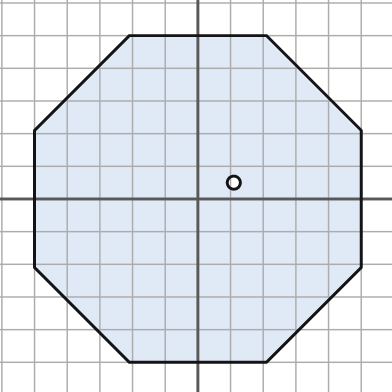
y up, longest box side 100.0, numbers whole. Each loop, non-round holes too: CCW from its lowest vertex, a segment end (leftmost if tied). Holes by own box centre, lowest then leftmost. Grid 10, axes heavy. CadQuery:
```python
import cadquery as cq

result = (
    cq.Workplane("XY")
    .moveTo(-21.0, -50.0)
    .lineTo(21.0, -50.0)
    .lineTo(50.0, -21.0)
    .lineTo(50.0, 21.0)
    .lineTo(21.0, 50.0)
    .lineTo(-21.0, 50.0)
    .lineTo(-50.0, 21.0)
    .lineTo(-50.0, -21.0)
    .close()
    .moveTo(11.0, 5.0)
    .circle(2.0)
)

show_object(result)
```